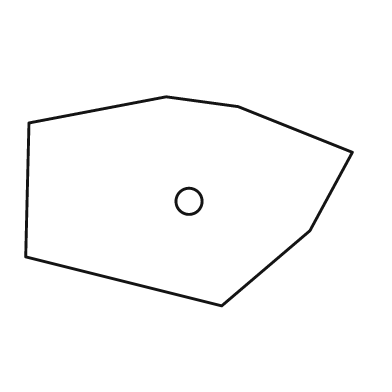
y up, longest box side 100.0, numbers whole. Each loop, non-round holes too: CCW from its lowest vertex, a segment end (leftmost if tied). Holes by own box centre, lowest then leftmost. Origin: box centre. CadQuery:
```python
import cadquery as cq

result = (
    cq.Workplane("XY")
    .moveTo(10.0, -32.0)
    .lineTo(37.0, -9.0)
    .lineTo(50.0, 15.0)
    .lineTo(15.0, 29.0)
    .lineTo(-7.0, 32.0)
    .lineTo(-49.0, 24.0)
    .lineTo(-50.0, -17.0)
    .close()
    .moveTo(0.0, 0.0)
    .circle(4.0)
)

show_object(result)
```